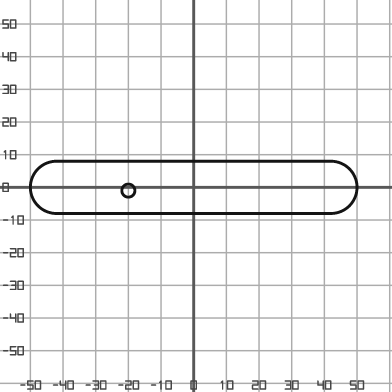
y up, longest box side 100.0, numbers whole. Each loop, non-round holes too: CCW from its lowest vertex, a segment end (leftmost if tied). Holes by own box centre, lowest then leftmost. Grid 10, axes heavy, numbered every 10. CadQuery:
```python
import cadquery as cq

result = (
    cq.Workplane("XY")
    .moveTo(-42.0, -8.0)
    .lineTo(42.0, -8.0)
    .threePointArc((50.0, 0.0), (42.0, 8.0))
    .lineTo(-42.0, 8.0)
    .threePointArc((-50.0, 0.0), (-42.0, -8.0))
    .close()
    .moveTo(-20.0, -1.0)
    .circle(2.0)
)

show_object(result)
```